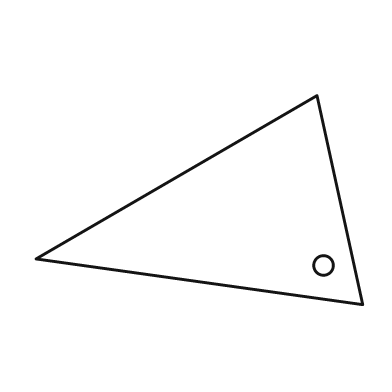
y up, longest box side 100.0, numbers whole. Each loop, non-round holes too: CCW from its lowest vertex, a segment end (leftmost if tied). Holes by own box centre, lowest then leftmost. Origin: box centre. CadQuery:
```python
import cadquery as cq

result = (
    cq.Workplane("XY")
    .moveTo(50.0, -32.0)
    .lineTo(36.0, 32.0)
    .lineTo(-50.0, -18.0)
    .close()
    .moveTo(38.0, -20.0)
    .circle(3.0)
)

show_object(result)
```